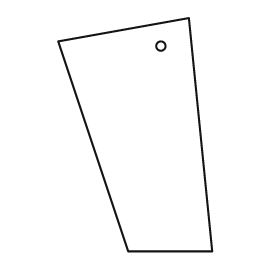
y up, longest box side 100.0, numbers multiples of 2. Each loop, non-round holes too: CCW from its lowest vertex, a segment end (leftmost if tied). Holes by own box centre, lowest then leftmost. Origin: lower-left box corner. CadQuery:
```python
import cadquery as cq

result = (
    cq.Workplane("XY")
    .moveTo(30.0, 0.0)
    .lineTo(66.0, 0.0)
    .lineTo(56.0, 100.0)
    .lineTo(0.0, 90.0)
    .close()
    .moveTo(44.0, 88.0)
    .circle(2.0)
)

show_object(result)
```